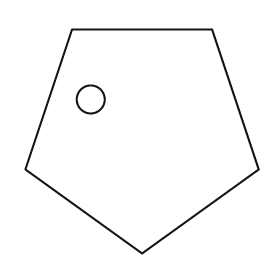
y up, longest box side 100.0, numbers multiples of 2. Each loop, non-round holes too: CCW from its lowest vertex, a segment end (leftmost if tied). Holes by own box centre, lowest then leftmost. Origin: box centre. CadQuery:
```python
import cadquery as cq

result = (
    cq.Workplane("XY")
    .moveTo(0.0, -48.0)
    .lineTo(50.0, -12.0)
    .lineTo(30.0, 48.0)
    .lineTo(-30.0, 48.0)
    .lineTo(-50.0, -12.0)
    .close()
    .moveTo(-22.0, 18.0)
    .circle(6.0)
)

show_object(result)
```